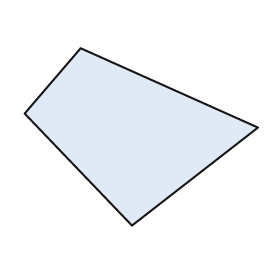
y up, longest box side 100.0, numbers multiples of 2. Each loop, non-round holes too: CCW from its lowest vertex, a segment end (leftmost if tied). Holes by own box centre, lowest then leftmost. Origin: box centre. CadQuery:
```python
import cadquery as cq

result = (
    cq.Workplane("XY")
    .moveTo(-4.0, -38.0)
    .lineTo(50.0, 4.0)
    .lineTo(-26.0, 38.0)
    .lineTo(-50.0, 10.0)
    .close()
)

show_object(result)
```